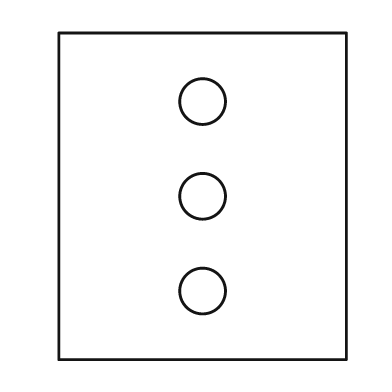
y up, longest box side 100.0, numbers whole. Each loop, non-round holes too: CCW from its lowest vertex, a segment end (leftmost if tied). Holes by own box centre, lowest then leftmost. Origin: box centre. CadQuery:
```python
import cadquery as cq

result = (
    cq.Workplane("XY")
    .moveTo(-44.0, -50.0)
    .lineTo(44.0, -50.0)
    .lineTo(44.0, 50.0)
    .lineTo(-44.0, 50.0)
    .close()
    .moveTo(0.0, -29.0)
    .circle(7.0)
    .moveTo(0.0, 0.0)
    .circle(7.0)
    .moveTo(0.0, 29.0)
    .circle(7.0)
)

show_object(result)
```